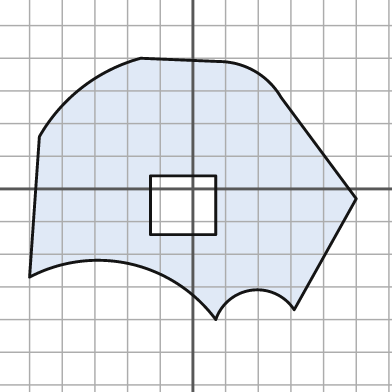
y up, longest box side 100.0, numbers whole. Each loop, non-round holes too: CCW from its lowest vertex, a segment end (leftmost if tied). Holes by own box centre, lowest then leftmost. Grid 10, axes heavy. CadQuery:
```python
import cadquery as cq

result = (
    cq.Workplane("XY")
    .moveTo(7.0, -40.0)
    .threePointArc((18.0, -31.0), (31.0, -37.0))
    .lineTo(50.0, -3.0)
    .lineTo(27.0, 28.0)
    .threePointArc((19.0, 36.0), (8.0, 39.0))
    .lineTo(-16.0, 40.0)
    .threePointArc((-34.0, 31.0), (-47.0, 16.0))
    .lineTo(-50.0, -27.0)
    .threePointArc((-19.0, -23.0), (7.0, -40.0))
    .close()
    .moveTo(-13.0, -14.0)
    .lineTo(7.0, -14.0)
    .lineTo(7.0, 4.0)
    .lineTo(-13.0, 4.0)
    .close()
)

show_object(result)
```